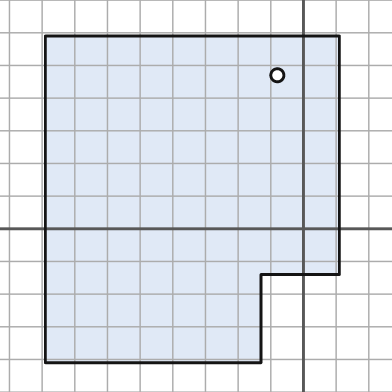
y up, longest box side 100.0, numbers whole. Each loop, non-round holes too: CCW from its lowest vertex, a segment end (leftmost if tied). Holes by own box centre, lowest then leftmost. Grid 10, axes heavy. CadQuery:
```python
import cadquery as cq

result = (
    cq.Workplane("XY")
    .moveTo(-79.0, -41.0)
    .lineTo(-13.0, -41.0)
    .lineTo(-13.0, -14.0)
    .lineTo(11.0, -14.0)
    .lineTo(11.0, 59.0)
    .lineTo(-79.0, 59.0)
    .close()
    .moveTo(-8.0, 47.0)
    .circle(2.0)
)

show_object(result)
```